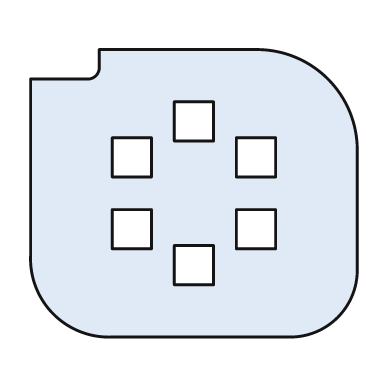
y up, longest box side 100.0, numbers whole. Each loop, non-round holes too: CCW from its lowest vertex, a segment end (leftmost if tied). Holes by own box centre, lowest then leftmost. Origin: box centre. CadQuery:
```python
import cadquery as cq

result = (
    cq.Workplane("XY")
    .moveTo(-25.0, -44.0)
    .lineTo(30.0, -44.0)
    .threePointArc((44.0, -38.0), (50.0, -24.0))
    .lineTo(50.0, 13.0)
    .threePointArc((41.0, 35.0), (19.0, 44.0))
    .lineTo(-29.0, 44.0)
    .lineTo(-29.0, 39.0)
    .threePointArc((-30.0, 36.0), (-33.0, 35.0))
    .lineTo(-50.0, 35.0)
    .lineTo(-50.0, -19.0)
    .threePointArc((-43.0, -37.0), (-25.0, -44.0))
    .close()
    .moveTo(-6.0, -28.0)
    .lineTo(6.0, -28.0)
    .lineTo(6.0, -16.0)
    .lineTo(-6.0, -16.0)
    .close()
    .moveTo(-25.0, -17.0)
    .lineTo(-13.0, -17.0)
    .lineTo(-13.0, -5.0)
    .lineTo(-25.0, -5.0)
    .close()
    .moveTo(13.0, -17.0)
    .lineTo(25.0, -17.0)
    .lineTo(25.0, -5.0)
    .lineTo(13.0, -5.0)
    .close()
    .moveTo(-25.0, 5.0)
    .lineTo(-13.0, 5.0)
    .lineTo(-13.0, 17.0)
    .lineTo(-25.0, 17.0)
    .close()
    .moveTo(13.0, 5.0)
    .lineTo(25.0, 5.0)
    .lineTo(25.0, 17.0)
    .lineTo(13.0, 17.0)
    .close()
    .moveTo(-6.0, 16.0)
    .lineTo(6.0, 16.0)
    .lineTo(6.0, 28.0)
    .lineTo(-6.0, 28.0)
    .close()
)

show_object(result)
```